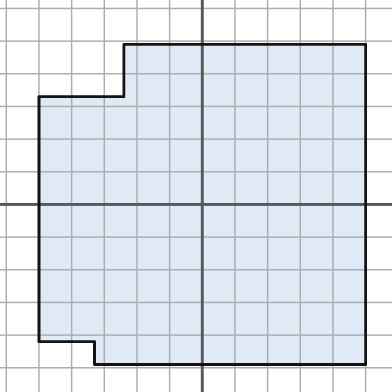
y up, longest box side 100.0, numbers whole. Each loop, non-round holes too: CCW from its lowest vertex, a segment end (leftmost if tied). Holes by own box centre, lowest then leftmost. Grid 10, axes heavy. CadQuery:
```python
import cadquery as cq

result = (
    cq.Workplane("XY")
    .moveTo(-33.0, -49.0)
    .lineTo(50.0, -49.0)
    .lineTo(50.0, 49.0)
    .lineTo(-24.0, 49.0)
    .lineTo(-24.0, 33.0)
    .lineTo(-50.0, 33.0)
    .lineTo(-50.0, -42.0)
    .lineTo(-33.0, -42.0)
    .close()
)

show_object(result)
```